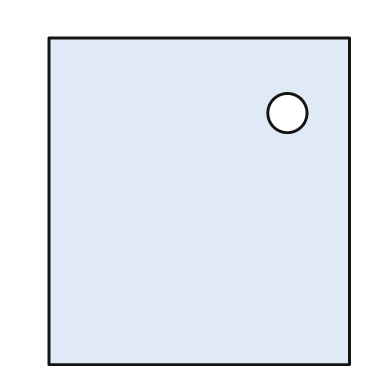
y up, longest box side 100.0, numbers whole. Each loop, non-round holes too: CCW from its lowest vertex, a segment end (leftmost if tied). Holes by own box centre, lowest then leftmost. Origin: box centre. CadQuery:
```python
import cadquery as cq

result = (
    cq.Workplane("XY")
    .moveTo(-46.0, -50.0)
    .lineTo(46.0, -50.0)
    .lineTo(46.0, 50.0)
    .lineTo(-46.0, 50.0)
    .close()
    .moveTo(27.0, 27.0)
    .circle(6.0)
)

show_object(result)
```